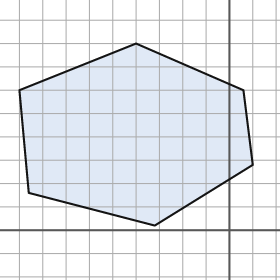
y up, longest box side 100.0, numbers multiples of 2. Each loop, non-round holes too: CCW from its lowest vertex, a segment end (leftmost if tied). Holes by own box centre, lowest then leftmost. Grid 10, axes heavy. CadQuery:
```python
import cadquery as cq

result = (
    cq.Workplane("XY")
    .moveTo(-32.0, 2.0)
    .lineTo(10.0, 28.0)
    .lineTo(6.0, 60.0)
    .lineTo(-40.0, 80.0)
    .lineTo(-90.0, 60.0)
    .lineTo(-86.0, 16.0)
    .close()
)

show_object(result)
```